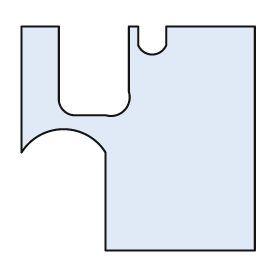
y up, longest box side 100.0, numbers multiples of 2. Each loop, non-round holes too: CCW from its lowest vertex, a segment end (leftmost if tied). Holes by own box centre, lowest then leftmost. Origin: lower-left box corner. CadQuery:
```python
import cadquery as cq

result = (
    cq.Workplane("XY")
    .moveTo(36.0, 0.0)
    .lineTo(100.0, 0.0)
    .lineTo(100.0, 96.0)
    .lineTo(62.0, 96.0)
    .lineTo(62.0, 88.0)
    .threePointArc((56.0, 84.0), (50.0, 88.0))
    .lineTo(50.0, 96.0)
    .lineTo(46.0, 96.0)
    .lineTo(46.0, 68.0)
    .threePointArc((44.0, 60.0), (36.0, 58.0))
    .lineTo(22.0, 58.0)
    .threePointArc((18.0, 60.0), (16.0, 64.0))
    .lineTo(16.0, 96.0)
    .lineTo(0.0, 96.0)
    .lineTo(0.0, 42.0)
    .threePointArc((18.0, 52.0), (36.0, 42.0))
    .close()
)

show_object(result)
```